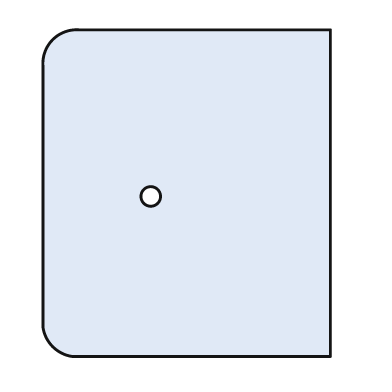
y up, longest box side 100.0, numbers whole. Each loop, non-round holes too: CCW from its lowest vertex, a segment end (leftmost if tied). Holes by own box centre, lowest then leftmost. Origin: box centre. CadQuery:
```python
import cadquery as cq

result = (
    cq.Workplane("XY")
    .moveTo(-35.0, -50.0)
    .lineTo(44.0, -50.0)
    .lineTo(44.0, 50.0)
    .lineTo(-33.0, 50.0)
    .threePointArc((-41.0, 47.0), (-44.0, 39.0))
    .lineTo(-44.0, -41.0)
    .threePointArc((-41.0, -47.0), (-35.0, -50.0))
    .close()
    .moveTo(-11.0, -1.0)
    .circle(3.0)
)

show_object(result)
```